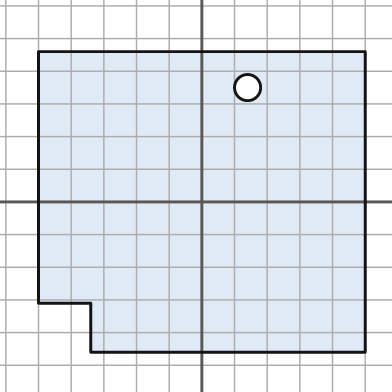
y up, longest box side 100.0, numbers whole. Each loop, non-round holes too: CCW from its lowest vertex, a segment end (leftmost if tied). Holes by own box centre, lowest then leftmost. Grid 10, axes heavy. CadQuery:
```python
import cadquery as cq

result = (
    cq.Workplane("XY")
    .moveTo(-34.0, -46.0)
    .lineTo(50.0, -46.0)
    .lineTo(50.0, 46.0)
    .lineTo(-50.0, 46.0)
    .lineTo(-50.0, -31.0)
    .lineTo(-34.0, -31.0)
    .close()
    .moveTo(14.0, 35.0)
    .circle(4.0)
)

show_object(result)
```